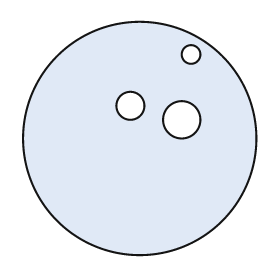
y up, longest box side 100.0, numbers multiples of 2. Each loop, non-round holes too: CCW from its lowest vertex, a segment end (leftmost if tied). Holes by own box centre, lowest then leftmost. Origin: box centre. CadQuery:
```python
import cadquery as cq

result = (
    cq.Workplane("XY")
    .moveTo(0.0, 0.0)
    .circle(50.0)
    .moveTo(18.0, 8.0)
    .circle(8.0)
    .moveTo(-4.0, 14.0)
    .circle(6.0)
    .moveTo(22.0, 36.0)
    .circle(4.0)
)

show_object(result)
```